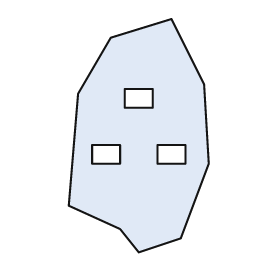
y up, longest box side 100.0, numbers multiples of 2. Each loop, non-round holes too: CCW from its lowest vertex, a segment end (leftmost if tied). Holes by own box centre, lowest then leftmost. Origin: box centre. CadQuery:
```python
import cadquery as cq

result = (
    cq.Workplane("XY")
    .moveTo(0.0, -50.0)
    .lineTo(18.0, -44.0)
    .lineTo(30.0, -12.0)
    .lineTo(28.0, 22.0)
    .lineTo(14.0, 50.0)
    .lineTo(-12.0, 42.0)
    .lineTo(-26.0, 18.0)
    .lineTo(-30.0, -30.0)
    .lineTo(-8.0, -40.0)
    .close()
    .moveTo(-20.0, -12.0)
    .lineTo(-8.0, -12.0)
    .lineTo(-8.0, -4.0)
    .lineTo(-20.0, -4.0)
    .close()
    .moveTo(8.0, -12.0)
    .lineTo(20.0, -12.0)
    .lineTo(20.0, -4.0)
    .lineTo(8.0, -4.0)
    .close()
    .moveTo(-6.0, 12.0)
    .lineTo(6.0, 12.0)
    .lineTo(6.0, 20.0)
    .lineTo(-6.0, 20.0)
    .close()
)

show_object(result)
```